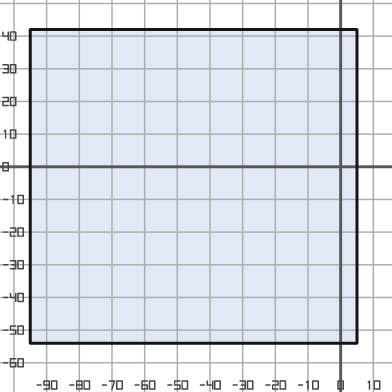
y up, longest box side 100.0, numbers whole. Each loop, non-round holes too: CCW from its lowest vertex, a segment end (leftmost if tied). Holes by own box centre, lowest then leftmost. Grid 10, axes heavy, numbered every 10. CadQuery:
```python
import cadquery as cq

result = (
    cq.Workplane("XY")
    .moveTo(-95.0, -54.0)
    .lineTo(5.0, -54.0)
    .lineTo(5.0, 42.0)
    .lineTo(-95.0, 42.0)
    .close()
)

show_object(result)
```